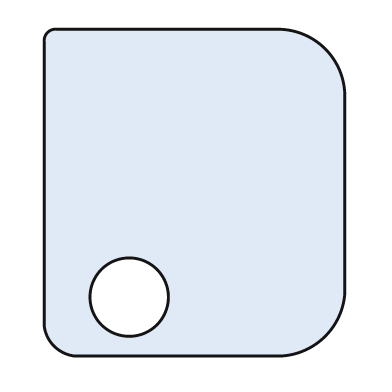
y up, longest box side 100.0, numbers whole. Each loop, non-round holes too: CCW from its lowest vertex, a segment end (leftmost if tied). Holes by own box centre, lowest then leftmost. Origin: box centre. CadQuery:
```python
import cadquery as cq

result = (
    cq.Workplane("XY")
    .moveTo(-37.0, -50.0)
    .lineTo(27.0, -50.0)
    .threePointArc((40.0, -44.0), (46.0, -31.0))
    .lineTo(46.0, 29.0)
    .threePointArc((40.0, 44.0), (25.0, 50.0))
    .lineTo(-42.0, 50.0)
    .threePointArc((-45.0, 49.0), (-46.0, 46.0))
    .lineTo(-46.0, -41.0)
    .threePointArc((-43.0, -47.0), (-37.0, -50.0))
    .close()
    .moveTo(-20.0, -32.0)
    .circle(12.0)
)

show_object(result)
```